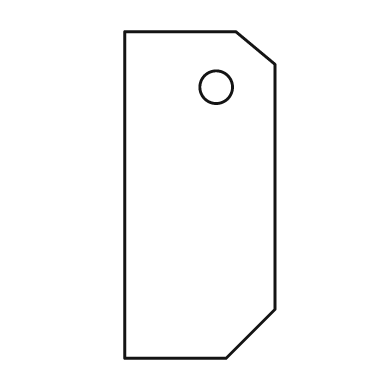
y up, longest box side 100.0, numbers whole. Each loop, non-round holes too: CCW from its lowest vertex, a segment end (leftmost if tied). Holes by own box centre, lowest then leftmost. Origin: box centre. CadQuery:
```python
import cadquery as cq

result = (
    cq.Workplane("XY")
    .moveTo(-23.0, -50.0)
    .lineTo(8.0, -50.0)
    .lineTo(23.0, -35.0)
    .lineTo(23.0, 40.0)
    .lineTo(11.0, 50.0)
    .lineTo(-23.0, 50.0)
    .close()
    .moveTo(5.0, 33.0)
    .circle(5.0)
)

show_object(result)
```